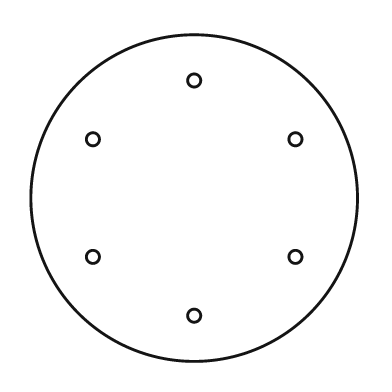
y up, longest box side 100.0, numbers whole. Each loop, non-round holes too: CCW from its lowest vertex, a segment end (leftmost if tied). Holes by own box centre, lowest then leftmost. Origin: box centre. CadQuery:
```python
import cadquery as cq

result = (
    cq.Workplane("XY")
    .moveTo(0.0, 0.0)
    .circle(50.0)
    .moveTo(0.0, -36.0)
    .circle(2.0)
    .moveTo(-31.0, -18.0)
    .circle(2.0)
    .moveTo(31.0, -18.0)
    .circle(2.0)
    .moveTo(-31.0, 18.0)
    .circle(2.0)
    .moveTo(31.0, 18.0)
    .circle(2.0)
    .moveTo(0.0, 36.0)
    .circle(2.0)
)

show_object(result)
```